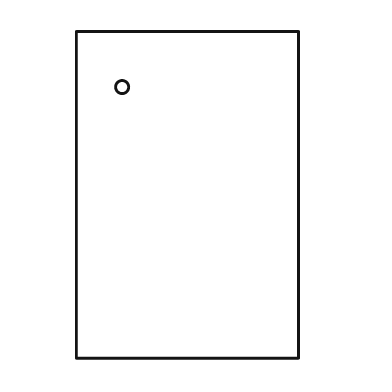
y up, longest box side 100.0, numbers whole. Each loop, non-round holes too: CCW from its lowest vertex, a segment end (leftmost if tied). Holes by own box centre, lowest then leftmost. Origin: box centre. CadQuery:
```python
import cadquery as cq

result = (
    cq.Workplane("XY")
    .moveTo(-34.0, -50.0)
    .lineTo(34.0, -50.0)
    .lineTo(34.0, 50.0)
    .lineTo(-34.0, 50.0)
    .close()
    .moveTo(-20.0, 33.0)
    .circle(2.0)
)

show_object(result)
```